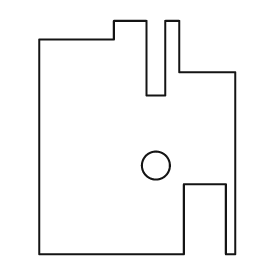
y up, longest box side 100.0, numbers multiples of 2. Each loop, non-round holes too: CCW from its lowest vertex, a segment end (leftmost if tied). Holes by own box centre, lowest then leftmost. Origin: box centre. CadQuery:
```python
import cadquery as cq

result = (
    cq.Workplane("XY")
    .moveTo(-42.0, -50.0)
    .lineTo(20.0, -50.0)
    .lineTo(20.0, -20.0)
    .lineTo(38.0, -20.0)
    .lineTo(38.0, -50.0)
    .lineTo(42.0, -50.0)
    .lineTo(42.0, 28.0)
    .lineTo(18.0, 28.0)
    .lineTo(18.0, 50.0)
    .lineTo(12.0, 50.0)
    .lineTo(12.0, 18.0)
    .lineTo(4.0, 18.0)
    .lineTo(4.0, 50.0)
    .lineTo(-10.0, 50.0)
    .lineTo(-10.0, 42.0)
    .lineTo(-42.0, 42.0)
    .close()
    .moveTo(8.0, -12.0)
    .circle(6.0)
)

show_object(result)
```